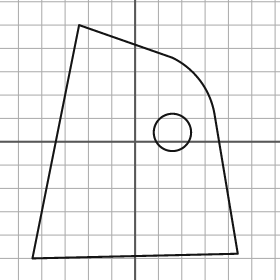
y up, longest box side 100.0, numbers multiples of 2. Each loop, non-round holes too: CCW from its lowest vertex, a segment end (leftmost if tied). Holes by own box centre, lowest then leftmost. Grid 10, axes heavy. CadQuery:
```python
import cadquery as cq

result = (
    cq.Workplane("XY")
    .moveTo(-44.0, -50.0)
    .lineTo(44.0, -48.0)
    .lineTo(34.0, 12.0)
    .threePointArc((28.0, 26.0), (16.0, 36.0))
    .lineTo(-24.0, 50.0)
    .close()
    .moveTo(16.0, 4.0)
    .circle(8.0)
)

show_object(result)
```